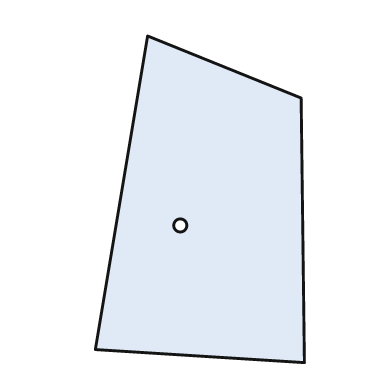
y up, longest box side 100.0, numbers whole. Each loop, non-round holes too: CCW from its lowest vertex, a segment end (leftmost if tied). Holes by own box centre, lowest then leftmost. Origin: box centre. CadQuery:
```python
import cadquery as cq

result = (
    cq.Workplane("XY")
    .moveTo(32.0, -50.0)
    .lineTo(31.0, 31.0)
    .lineTo(-16.0, 50.0)
    .lineTo(-32.0, -46.0)
    .close()
    .moveTo(-6.0, -8.0)
    .circle(2.0)
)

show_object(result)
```